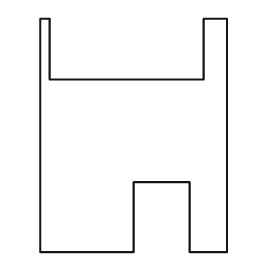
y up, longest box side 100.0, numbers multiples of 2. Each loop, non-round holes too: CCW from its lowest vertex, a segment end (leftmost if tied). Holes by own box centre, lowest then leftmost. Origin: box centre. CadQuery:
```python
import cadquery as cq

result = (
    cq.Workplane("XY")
    .moveTo(-40.0, -50.0)
    .lineTo(0.0, -50.0)
    .lineTo(0.0, -20.0)
    .lineTo(24.0, -20.0)
    .lineTo(24.0, -50.0)
    .lineTo(40.0, -50.0)
    .lineTo(40.0, 50.0)
    .lineTo(30.0, 50.0)
    .lineTo(30.0, 24.0)
    .lineTo(-36.0, 24.0)
    .lineTo(-36.0, 50.0)
    .lineTo(-40.0, 50.0)
    .close()
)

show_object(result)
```